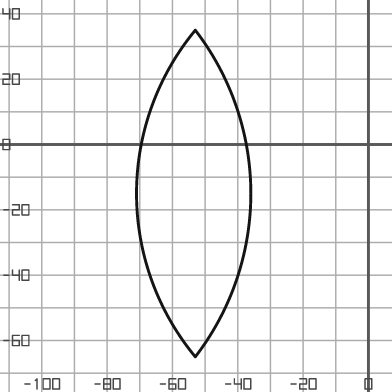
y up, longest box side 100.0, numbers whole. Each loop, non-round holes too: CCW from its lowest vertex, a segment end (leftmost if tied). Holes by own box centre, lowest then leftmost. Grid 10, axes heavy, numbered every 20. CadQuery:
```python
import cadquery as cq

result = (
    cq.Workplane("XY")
    .moveTo(-53.0, -65.0)
    .threePointArc((-36.0, -15.0), (-53.0, 35.0))
    .threePointArc((-71.0, -15.0), (-53.0, -65.0))
    .close()
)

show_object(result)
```